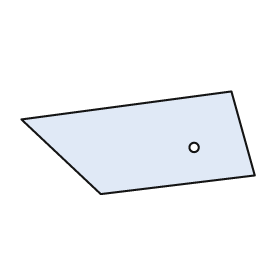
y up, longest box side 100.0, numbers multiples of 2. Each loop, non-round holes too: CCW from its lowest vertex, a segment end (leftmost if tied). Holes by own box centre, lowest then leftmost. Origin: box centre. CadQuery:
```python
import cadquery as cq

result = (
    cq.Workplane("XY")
    .moveTo(-16.0, -22.0)
    .lineTo(50.0, -14.0)
    .lineTo(40.0, 22.0)
    .lineTo(-50.0, 10.0)
    .close()
    .moveTo(24.0, -2.0)
    .circle(2.0)
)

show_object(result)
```